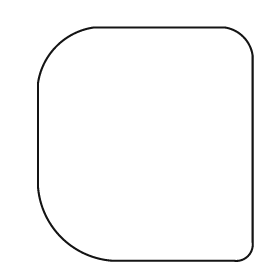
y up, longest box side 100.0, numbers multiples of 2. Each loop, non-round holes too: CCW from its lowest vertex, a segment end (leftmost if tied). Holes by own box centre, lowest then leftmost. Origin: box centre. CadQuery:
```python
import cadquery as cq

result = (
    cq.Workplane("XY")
    .moveTo(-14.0, -50.0)
    .lineTo(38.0, -50.0)
    .threePointArc((44.0, -48.0), (46.0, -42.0))
    .lineTo(46.0, 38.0)
    .threePointArc((42.0, 46.0), (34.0, 50.0))
    .lineTo(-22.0, 50.0)
    .threePointArc((-38.0, 42.0), (-46.0, 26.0))
    .lineTo(-46.0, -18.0)
    .threePointArc((-36.0, -40.0), (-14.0, -50.0))
    .close()
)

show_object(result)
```